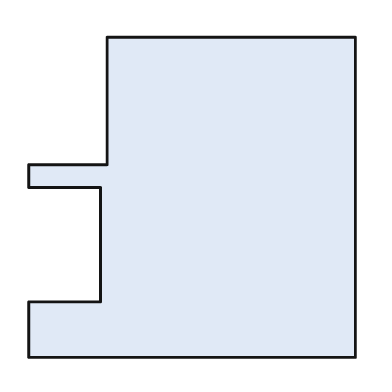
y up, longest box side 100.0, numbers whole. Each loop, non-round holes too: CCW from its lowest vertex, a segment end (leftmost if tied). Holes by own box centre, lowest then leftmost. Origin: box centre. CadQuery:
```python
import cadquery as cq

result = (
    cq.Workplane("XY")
    .moveTo(-50.0, -49.0)
    .lineTo(50.0, -49.0)
    .lineTo(50.0, 49.0)
    .lineTo(-26.0, 49.0)
    .lineTo(-26.0, 10.0)
    .lineTo(-50.0, 10.0)
    .lineTo(-50.0, 3.0)
    .lineTo(-28.0, 3.0)
    .lineTo(-28.0, -32.0)
    .lineTo(-50.0, -32.0)
    .close()
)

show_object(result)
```